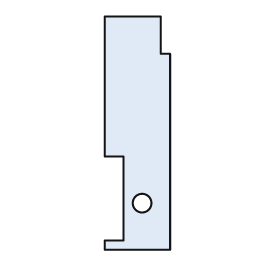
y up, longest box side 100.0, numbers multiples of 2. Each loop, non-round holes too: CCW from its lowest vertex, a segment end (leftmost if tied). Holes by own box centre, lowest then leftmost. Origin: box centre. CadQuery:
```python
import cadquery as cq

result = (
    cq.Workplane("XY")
    .moveTo(-14.0, -50.0)
    .lineTo(14.0, -50.0)
    .lineTo(14.0, 34.0)
    .lineTo(10.0, 34.0)
    .lineTo(10.0, 50.0)
    .lineTo(-14.0, 50.0)
    .lineTo(-14.0, -10.0)
    .lineTo(-6.0, -10.0)
    .lineTo(-6.0, -46.0)
    .lineTo(-14.0, -46.0)
    .close()
    .moveTo(2.0, -30.0)
    .circle(4.0)
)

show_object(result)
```